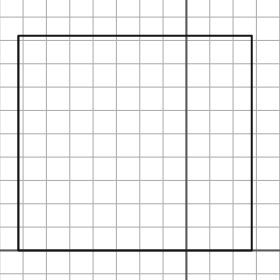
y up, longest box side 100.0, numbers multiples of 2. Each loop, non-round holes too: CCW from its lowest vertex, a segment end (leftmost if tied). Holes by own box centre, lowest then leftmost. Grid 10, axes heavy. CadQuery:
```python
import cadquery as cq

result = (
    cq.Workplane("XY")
    .moveTo(-72.0, 0.0)
    .lineTo(28.0, 0.0)
    .lineTo(28.0, 92.0)
    .lineTo(-72.0, 92.0)
    .close()
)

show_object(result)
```